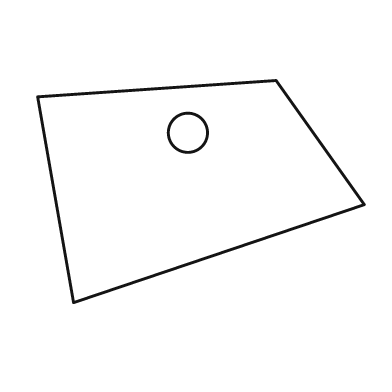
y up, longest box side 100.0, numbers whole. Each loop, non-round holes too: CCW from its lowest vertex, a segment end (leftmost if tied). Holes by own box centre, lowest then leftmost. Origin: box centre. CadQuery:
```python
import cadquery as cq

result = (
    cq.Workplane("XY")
    .moveTo(-39.0, -34.0)
    .lineTo(50.0, -4.0)
    .lineTo(23.0, 34.0)
    .lineTo(-50.0, 29.0)
    .close()
    .moveTo(-4.0, 18.0)
    .circle(6.0)
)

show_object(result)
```